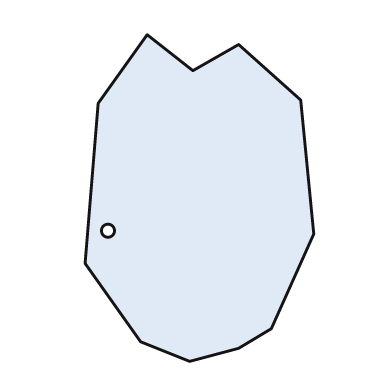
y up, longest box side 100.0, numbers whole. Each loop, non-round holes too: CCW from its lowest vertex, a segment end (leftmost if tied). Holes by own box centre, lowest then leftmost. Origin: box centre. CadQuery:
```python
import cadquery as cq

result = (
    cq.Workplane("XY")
    .moveTo(-3.0, -50.0)
    .lineTo(12.0, -46.0)
    .lineTo(22.0, -40.0)
    .lineTo(35.0, -11.0)
    .lineTo(31.0, 30.0)
    .lineTo(12.0, 47.0)
    .lineTo(-2.0, 39.0)
    .lineTo(-16.0, 50.0)
    .lineTo(-31.0, 29.0)
    .lineTo(-35.0, -20.0)
    .lineTo(-18.0, -44.0)
    .close()
    .moveTo(-28.0, -10.0)
    .circle(2.0)
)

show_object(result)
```